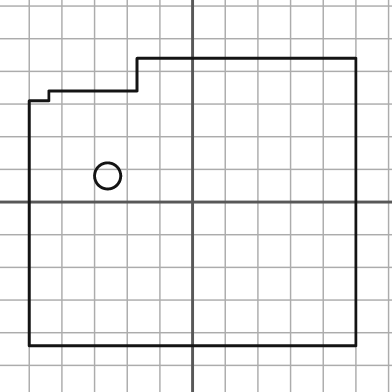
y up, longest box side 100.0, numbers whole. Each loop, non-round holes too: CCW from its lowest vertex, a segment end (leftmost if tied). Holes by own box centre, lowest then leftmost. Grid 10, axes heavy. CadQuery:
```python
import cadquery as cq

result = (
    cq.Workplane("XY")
    .moveTo(-50.0, -44.0)
    .lineTo(50.0, -44.0)
    .lineTo(50.0, 44.0)
    .lineTo(-17.0, 44.0)
    .lineTo(-17.0, 34.0)
    .lineTo(-44.0, 34.0)
    .lineTo(-44.0, 31.0)
    .lineTo(-50.0, 31.0)
    .close()
    .moveTo(-26.0, 8.0)
    .circle(4.0)
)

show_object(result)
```